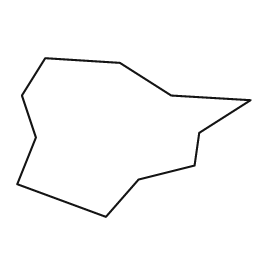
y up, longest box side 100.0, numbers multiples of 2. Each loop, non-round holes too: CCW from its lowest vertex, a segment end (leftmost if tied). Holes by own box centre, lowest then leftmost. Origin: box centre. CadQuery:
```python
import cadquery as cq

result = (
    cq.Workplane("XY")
    .moveTo(-12.0, -34.0)
    .lineTo(2.0, -18.0)
    .lineTo(26.0, -12.0)
    .lineTo(28.0, 2.0)
    .lineTo(50.0, 16.0)
    .lineTo(16.0, 18.0)
    .lineTo(-6.0, 32.0)
    .lineTo(-38.0, 34.0)
    .lineTo(-48.0, 18.0)
    .lineTo(-42.0, 0.0)
    .lineTo(-50.0, -20.0)
    .close()
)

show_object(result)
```